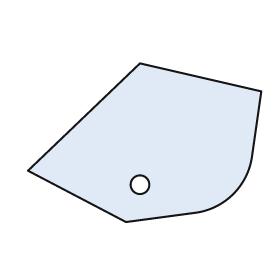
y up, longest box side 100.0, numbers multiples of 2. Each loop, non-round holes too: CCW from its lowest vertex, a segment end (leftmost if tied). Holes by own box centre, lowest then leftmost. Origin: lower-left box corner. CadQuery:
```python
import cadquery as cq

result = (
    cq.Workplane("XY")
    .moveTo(42.0, 0.0)
    .lineTo(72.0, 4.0)
    .threePointArc((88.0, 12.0), (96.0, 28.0))
    .lineTo(100.0, 56.0)
    .lineTo(48.0, 68.0)
    .lineTo(0.0, 22.0)
    .close()
    .moveTo(48.0, 16.0)
    .circle(4.0)
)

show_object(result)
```